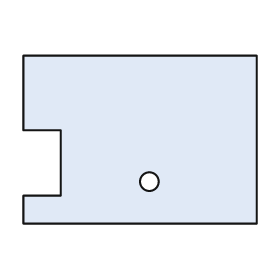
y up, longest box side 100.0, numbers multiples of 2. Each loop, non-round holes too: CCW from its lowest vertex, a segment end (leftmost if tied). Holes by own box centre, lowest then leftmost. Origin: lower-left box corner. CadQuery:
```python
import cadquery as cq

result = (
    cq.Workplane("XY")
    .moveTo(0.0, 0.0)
    .lineTo(100.0, 0.0)
    .lineTo(100.0, 72.0)
    .lineTo(0.0, 72.0)
    .lineTo(0.0, 40.0)
    .lineTo(16.0, 40.0)
    .lineTo(16.0, 12.0)
    .lineTo(0.0, 12.0)
    .close()
    .moveTo(54.0, 18.0)
    .circle(4.0)
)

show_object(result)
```